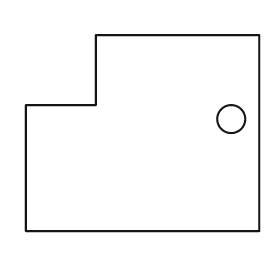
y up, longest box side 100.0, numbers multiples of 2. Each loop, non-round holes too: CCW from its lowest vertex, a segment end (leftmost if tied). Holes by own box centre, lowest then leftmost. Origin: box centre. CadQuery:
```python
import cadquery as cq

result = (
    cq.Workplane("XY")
    .moveTo(-50.0, -42.0)
    .lineTo(50.0, -42.0)
    .lineTo(50.0, 42.0)
    .lineTo(-20.0, 42.0)
    .lineTo(-20.0, 12.0)
    .lineTo(-50.0, 12.0)
    .close()
    .moveTo(38.0, 6.0)
    .circle(6.0)
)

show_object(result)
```